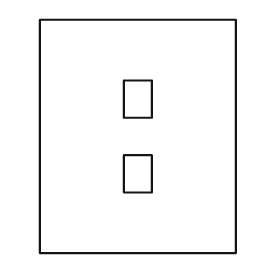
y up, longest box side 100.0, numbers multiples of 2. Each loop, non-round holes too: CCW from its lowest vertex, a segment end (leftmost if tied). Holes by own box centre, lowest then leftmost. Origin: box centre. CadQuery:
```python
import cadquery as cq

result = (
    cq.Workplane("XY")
    .moveTo(-42.0, -50.0)
    .lineTo(42.0, -50.0)
    .lineTo(42.0, 50.0)
    .lineTo(-42.0, 50.0)
    .close()
    .moveTo(-6.0, -24.0)
    .lineTo(6.0, -24.0)
    .lineTo(6.0, -8.0)
    .lineTo(-6.0, -8.0)
    .close()
    .moveTo(-6.0, 8.0)
    .lineTo(6.0, 8.0)
    .lineTo(6.0, 24.0)
    .lineTo(-6.0, 24.0)
    .close()
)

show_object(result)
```